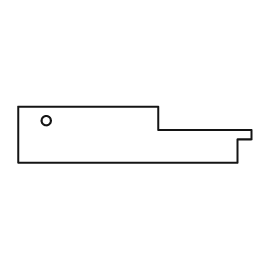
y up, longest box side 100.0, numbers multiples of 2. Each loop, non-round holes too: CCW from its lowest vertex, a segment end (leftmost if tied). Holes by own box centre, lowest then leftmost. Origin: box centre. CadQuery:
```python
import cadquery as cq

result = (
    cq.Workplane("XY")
    .moveTo(-50.0, -12.0)
    .lineTo(44.0, -12.0)
    .lineTo(44.0, -2.0)
    .lineTo(50.0, -2.0)
    .lineTo(50.0, 2.0)
    .lineTo(10.0, 2.0)
    .lineTo(10.0, 12.0)
    .lineTo(-50.0, 12.0)
    .close()
    .moveTo(-38.0, 6.0)
    .circle(2.0)
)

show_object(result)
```